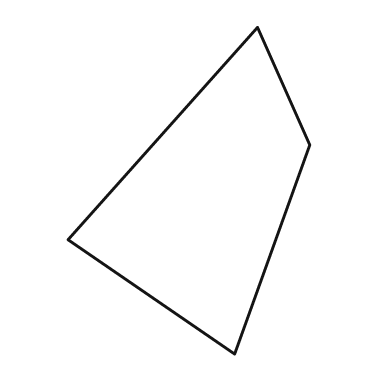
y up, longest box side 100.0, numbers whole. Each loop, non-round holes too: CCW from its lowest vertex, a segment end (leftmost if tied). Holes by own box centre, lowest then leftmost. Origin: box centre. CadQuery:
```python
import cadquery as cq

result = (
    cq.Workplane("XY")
    .moveTo(14.0, -50.0)
    .lineTo(37.0, 14.0)
    .lineTo(21.0, 50.0)
    .lineTo(-37.0, -15.0)
    .close()
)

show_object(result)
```